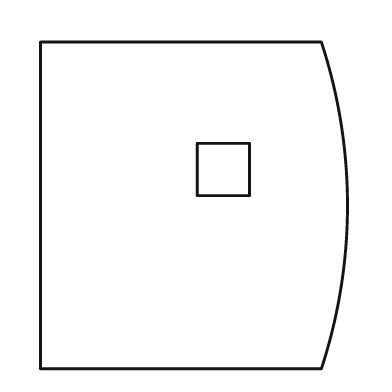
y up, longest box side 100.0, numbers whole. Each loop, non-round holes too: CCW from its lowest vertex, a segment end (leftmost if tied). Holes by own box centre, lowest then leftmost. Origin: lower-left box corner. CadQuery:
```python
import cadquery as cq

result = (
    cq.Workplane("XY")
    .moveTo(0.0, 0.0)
    .lineTo(86.0, 0.0)
    .threePointArc((94.0, 50.0), (86.0, 100.0))
    .lineTo(0.0, 100.0)
    .close()
    .moveTo(48.0, 53.0)
    .lineTo(64.0, 53.0)
    .lineTo(64.0, 69.0)
    .lineTo(48.0, 69.0)
    .close()
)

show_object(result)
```